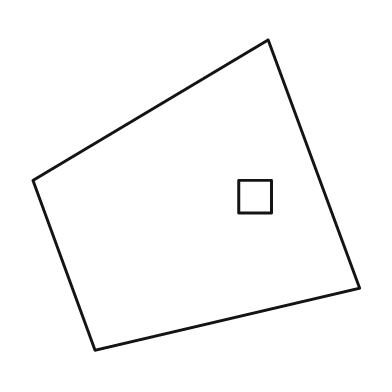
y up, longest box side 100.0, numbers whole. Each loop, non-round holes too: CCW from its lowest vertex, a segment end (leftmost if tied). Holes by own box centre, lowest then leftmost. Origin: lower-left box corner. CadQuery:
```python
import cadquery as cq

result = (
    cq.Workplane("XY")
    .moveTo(19.0, 0.0)
    .lineTo(100.0, 19.0)
    .lineTo(72.0, 95.0)
    .lineTo(0.0, 52.0)
    .close()
    .moveTo(63.0, 42.0)
    .lineTo(73.0, 42.0)
    .lineTo(73.0, 52.0)
    .lineTo(63.0, 52.0)
    .close()
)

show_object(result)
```